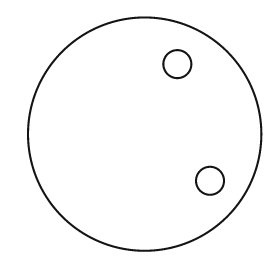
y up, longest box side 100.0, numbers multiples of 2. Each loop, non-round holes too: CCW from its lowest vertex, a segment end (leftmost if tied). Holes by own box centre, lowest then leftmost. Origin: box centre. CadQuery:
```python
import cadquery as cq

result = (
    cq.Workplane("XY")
    .moveTo(0.0, 0.0)
    .circle(50.0)
    .moveTo(28.0, -20.0)
    .circle(6.0)
    .moveTo(14.0, 30.0)
    .circle(6.0)
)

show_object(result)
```